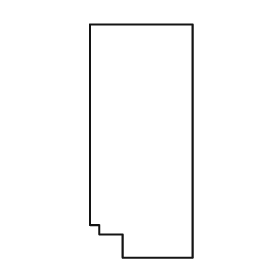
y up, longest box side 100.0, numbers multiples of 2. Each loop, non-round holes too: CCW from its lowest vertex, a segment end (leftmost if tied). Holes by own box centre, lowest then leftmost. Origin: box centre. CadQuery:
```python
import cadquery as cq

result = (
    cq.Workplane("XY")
    .moveTo(-8.0, -50.0)
    .lineTo(22.0, -50.0)
    .lineTo(22.0, 50.0)
    .lineTo(-22.0, 50.0)
    .lineTo(-22.0, -36.0)
    .lineTo(-18.0, -36.0)
    .lineTo(-18.0, -40.0)
    .lineTo(-8.0, -40.0)
    .close()
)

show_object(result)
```